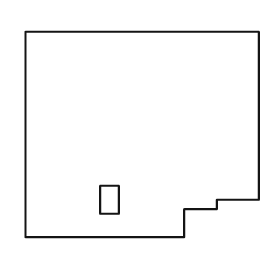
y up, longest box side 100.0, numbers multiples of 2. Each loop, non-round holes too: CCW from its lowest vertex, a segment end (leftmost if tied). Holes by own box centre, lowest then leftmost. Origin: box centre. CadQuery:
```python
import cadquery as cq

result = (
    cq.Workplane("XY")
    .moveTo(-50.0, -44.0)
    .lineTo(18.0, -44.0)
    .lineTo(18.0, -32.0)
    .lineTo(32.0, -32.0)
    .lineTo(32.0, -28.0)
    .lineTo(50.0, -28.0)
    .lineTo(50.0, 44.0)
    .lineTo(-50.0, 44.0)
    .close()
    .moveTo(-18.0, -34.0)
    .lineTo(-10.0, -34.0)
    .lineTo(-10.0, -22.0)
    .lineTo(-18.0, -22.0)
    .close()
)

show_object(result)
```